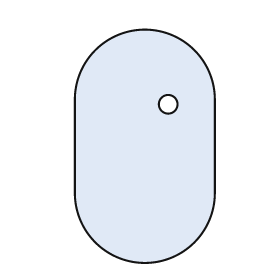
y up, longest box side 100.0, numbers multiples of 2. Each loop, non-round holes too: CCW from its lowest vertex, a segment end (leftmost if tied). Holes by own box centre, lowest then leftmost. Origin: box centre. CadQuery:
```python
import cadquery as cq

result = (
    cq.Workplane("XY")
    .moveTo(-30.0, -20.0)
    .threePointArc((0.0, -50.0), (30.0, -20.0))
    .lineTo(30.0, 20.0)
    .threePointArc((0.0, 50.0), (-30.0, 20.0))
    .close()
    .moveTo(10.0, 18.0)
    .circle(4.0)
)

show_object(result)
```